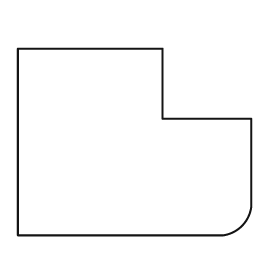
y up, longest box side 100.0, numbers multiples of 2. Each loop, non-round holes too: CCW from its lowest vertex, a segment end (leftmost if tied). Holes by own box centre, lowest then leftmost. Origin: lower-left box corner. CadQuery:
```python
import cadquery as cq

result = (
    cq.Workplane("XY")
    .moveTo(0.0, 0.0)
    .lineTo(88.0, 0.0)
    .threePointArc((96.0, 4.0), (100.0, 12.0))
    .lineTo(100.0, 50.0)
    .lineTo(62.0, 50.0)
    .lineTo(62.0, 80.0)
    .lineTo(0.0, 80.0)
    .close()
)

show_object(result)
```